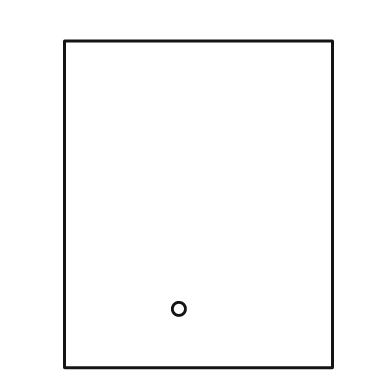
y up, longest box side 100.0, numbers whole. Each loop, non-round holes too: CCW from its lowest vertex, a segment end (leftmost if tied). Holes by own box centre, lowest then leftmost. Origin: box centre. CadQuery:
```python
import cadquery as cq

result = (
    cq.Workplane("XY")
    .moveTo(-41.0, -50.0)
    .lineTo(41.0, -50.0)
    .lineTo(41.0, 50.0)
    .lineTo(-41.0, 50.0)
    .close()
    .moveTo(-6.0, -32.0)
    .circle(2.0)
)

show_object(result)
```